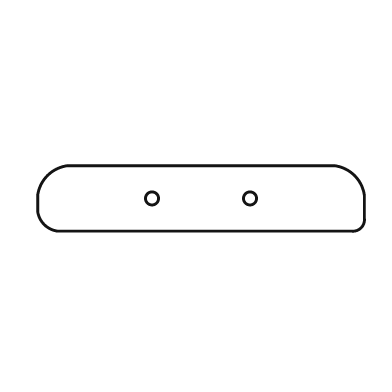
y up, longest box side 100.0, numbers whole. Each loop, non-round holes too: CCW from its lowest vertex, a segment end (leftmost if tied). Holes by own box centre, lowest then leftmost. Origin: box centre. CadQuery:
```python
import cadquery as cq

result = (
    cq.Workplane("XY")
    .moveTo(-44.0, -10.0)
    .lineTo(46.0, -10.0)
    .threePointArc((49.0, -9.0), (50.0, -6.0))
    .lineTo(50.0, 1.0)
    .threePointArc((47.0, 7.0), (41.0, 10.0))
    .lineTo(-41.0, 10.0)
    .threePointArc((-47.0, 7.0), (-50.0, 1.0))
    .lineTo(-50.0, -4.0)
    .threePointArc((-48.0, -8.0), (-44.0, -10.0))
    .close()
    .moveTo(-15.0, 0.0)
    .circle(2.0)
    .moveTo(15.0, 0.0)
    .circle(2.0)
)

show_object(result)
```